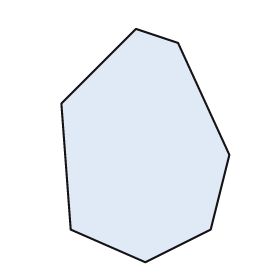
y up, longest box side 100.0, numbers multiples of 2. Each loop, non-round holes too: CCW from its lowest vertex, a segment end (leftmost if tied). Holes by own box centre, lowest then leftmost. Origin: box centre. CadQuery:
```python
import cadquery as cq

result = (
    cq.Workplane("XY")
    .moveTo(0.0, -50.0)
    .lineTo(28.0, -36.0)
    .lineTo(36.0, -4.0)
    .lineTo(14.0, 44.0)
    .lineTo(-4.0, 50.0)
    .lineTo(-36.0, 18.0)
    .lineTo(-32.0, -36.0)
    .close()
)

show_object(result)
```